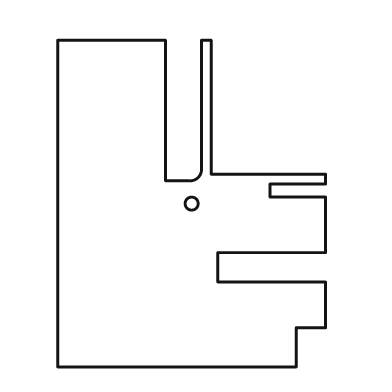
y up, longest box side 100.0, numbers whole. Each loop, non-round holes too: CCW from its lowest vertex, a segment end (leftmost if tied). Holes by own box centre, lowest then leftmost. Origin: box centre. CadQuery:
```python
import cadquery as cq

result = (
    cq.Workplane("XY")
    .moveTo(-41.0, -50.0)
    .lineTo(32.0, -50.0)
    .lineTo(32.0, -38.0)
    .lineTo(41.0, -38.0)
    .lineTo(41.0, -24.0)
    .lineTo(8.0, -24.0)
    .lineTo(8.0, -15.0)
    .lineTo(41.0, -15.0)
    .lineTo(41.0, 2.0)
    .lineTo(24.0, 2.0)
    .lineTo(24.0, 6.0)
    .lineTo(41.0, 6.0)
    .lineTo(41.0, 9.0)
    .lineTo(6.0, 9.0)
    .lineTo(6.0, 50.0)
    .lineTo(3.0, 50.0)
    .lineTo(3.0, 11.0)
    .threePointArc((2.0, 8.0), (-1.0, 7.0))
    .lineTo(-8.0, 7.0)
    .lineTo(-8.0, 50.0)
    .lineTo(-41.0, 50.0)
    .close()
    .moveTo(0.0, 0.0)
    .circle(2.0)
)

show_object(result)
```